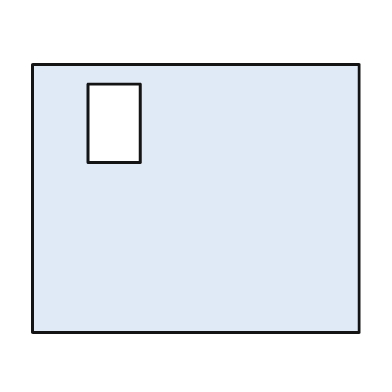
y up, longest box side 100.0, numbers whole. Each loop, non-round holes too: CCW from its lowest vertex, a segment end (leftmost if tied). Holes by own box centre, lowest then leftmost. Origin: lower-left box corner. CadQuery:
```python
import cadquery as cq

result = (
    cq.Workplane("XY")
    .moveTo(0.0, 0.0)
    .lineTo(100.0, 0.0)
    .lineTo(100.0, 82.0)
    .lineTo(0.0, 82.0)
    .close()
    .moveTo(17.0, 52.0)
    .lineTo(33.0, 52.0)
    .lineTo(33.0, 76.0)
    .lineTo(17.0, 76.0)
    .close()
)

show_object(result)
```